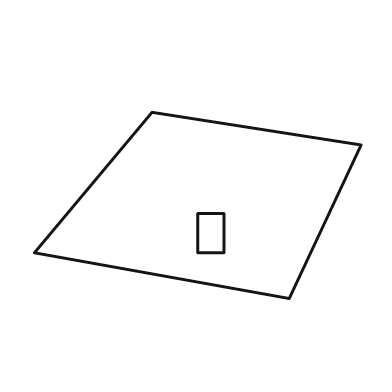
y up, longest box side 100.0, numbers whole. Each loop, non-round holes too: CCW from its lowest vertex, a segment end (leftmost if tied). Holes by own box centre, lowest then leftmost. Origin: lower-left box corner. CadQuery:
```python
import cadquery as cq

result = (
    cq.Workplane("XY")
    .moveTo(78.0, 0.0)
    .lineTo(100.0, 47.0)
    .lineTo(36.0, 57.0)
    .lineTo(0.0, 14.0)
    .close()
    .moveTo(50.0, 14.0)
    .lineTo(58.0, 14.0)
    .lineTo(58.0, 26.0)
    .lineTo(50.0, 26.0)
    .close()
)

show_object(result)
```